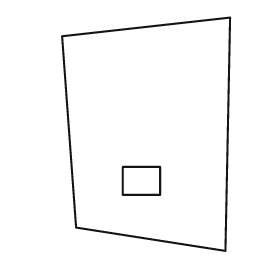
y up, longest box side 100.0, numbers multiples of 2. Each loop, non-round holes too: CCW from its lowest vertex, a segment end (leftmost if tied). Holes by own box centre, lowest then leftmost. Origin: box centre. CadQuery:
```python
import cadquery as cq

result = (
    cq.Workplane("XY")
    .moveTo(34.0, -50.0)
    .lineTo(36.0, 50.0)
    .lineTo(-36.0, 42.0)
    .lineTo(-30.0, -40.0)
    .close()
    .moveTo(-10.0, -26.0)
    .lineTo(6.0, -26.0)
    .lineTo(6.0, -14.0)
    .lineTo(-10.0, -14.0)
    .close()
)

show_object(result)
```